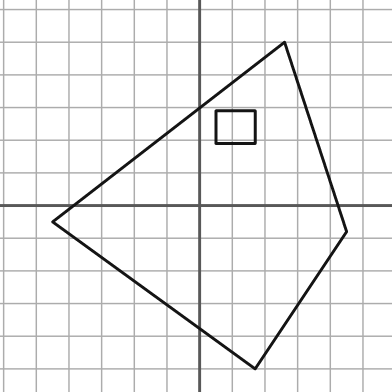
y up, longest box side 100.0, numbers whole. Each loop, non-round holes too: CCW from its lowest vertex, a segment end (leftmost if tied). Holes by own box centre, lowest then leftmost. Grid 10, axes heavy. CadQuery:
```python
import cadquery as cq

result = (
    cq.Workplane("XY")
    .moveTo(17.0, -50.0)
    .lineTo(45.0, -8.0)
    .lineTo(26.0, 50.0)
    .lineTo(-45.0, -5.0)
    .close()
    .moveTo(5.0, 19.0)
    .lineTo(17.0, 19.0)
    .lineTo(17.0, 29.0)
    .lineTo(5.0, 29.0)
    .close()
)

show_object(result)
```